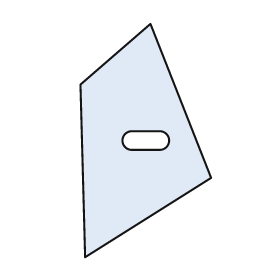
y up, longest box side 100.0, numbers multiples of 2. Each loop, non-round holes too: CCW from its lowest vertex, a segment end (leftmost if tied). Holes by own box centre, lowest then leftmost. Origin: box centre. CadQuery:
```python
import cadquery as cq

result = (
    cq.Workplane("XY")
    .moveTo(-26.0, -50.0)
    .lineTo(28.0, -16.0)
    .lineTo(2.0, 50.0)
    .lineTo(-28.0, 24.0)
    .close()
    .moveTo(-6.0, -4.0)
    .lineTo(6.0, -4.0)
    .threePointArc((10.0, 0.0), (6.0, 4.0))
    .lineTo(-6.0, 4.0)
    .threePointArc((-10.0, 0.0), (-6.0, -4.0))
    .close()
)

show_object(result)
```